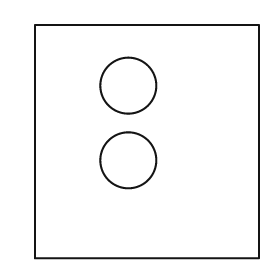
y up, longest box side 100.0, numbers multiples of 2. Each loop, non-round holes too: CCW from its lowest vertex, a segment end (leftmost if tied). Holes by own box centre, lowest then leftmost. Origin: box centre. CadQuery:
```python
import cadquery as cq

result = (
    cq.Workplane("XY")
    .moveTo(-48.0, -50.0)
    .lineTo(48.0, -50.0)
    .lineTo(48.0, 50.0)
    .lineTo(-48.0, 50.0)
    .close()
    .moveTo(-8.0, -8.0)
    .circle(12.0)
    .moveTo(-8.0, 24.0)
    .circle(12.0)
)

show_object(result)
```